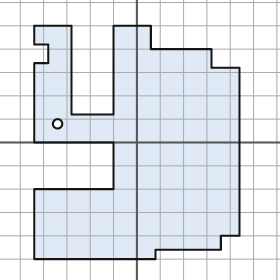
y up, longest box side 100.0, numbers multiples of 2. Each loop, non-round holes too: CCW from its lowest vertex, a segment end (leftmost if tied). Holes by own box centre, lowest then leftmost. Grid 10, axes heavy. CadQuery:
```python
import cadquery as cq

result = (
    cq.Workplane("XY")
    .moveTo(-44.0, -50.0)
    .lineTo(8.0, -50.0)
    .lineTo(8.0, -46.0)
    .lineTo(36.0, -46.0)
    .lineTo(36.0, -40.0)
    .lineTo(44.0, -40.0)
    .lineTo(44.0, 32.0)
    .lineTo(32.0, 32.0)
    .lineTo(32.0, 40.0)
    .lineTo(6.0, 40.0)
    .lineTo(6.0, 50.0)
    .lineTo(-10.0, 50.0)
    .lineTo(-10.0, 12.0)
    .lineTo(-28.0, 12.0)
    .lineTo(-28.0, 50.0)
    .lineTo(-44.0, 50.0)
    .lineTo(-44.0, 42.0)
    .lineTo(-38.0, 42.0)
    .lineTo(-38.0, 34.0)
    .lineTo(-44.0, 34.0)
    .lineTo(-44.0, 0.0)
    .lineTo(-10.0, 0.0)
    .lineTo(-10.0, -20.0)
    .lineTo(-44.0, -20.0)
    .close()
    .moveTo(-34.0, 8.0)
    .circle(2.0)
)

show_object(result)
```